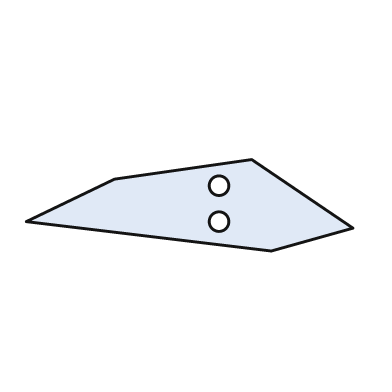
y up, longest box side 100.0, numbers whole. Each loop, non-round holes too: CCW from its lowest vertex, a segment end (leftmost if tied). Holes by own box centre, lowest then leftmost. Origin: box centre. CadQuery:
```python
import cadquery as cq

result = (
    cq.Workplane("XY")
    .moveTo(25.0, -14.0)
    .lineTo(50.0, -7.0)
    .lineTo(19.0, 14.0)
    .lineTo(-23.0, 8.0)
    .lineTo(-50.0, -5.0)
    .close()
    .moveTo(9.0, -5.0)
    .circle(3.0)
    .moveTo(9.0, 6.0)
    .circle(3.0)
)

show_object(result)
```